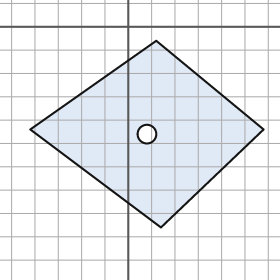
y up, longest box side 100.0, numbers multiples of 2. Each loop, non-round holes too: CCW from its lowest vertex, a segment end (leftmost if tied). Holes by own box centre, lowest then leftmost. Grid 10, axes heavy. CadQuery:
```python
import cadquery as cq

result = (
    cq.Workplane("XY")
    .moveTo(14.0, -86.0)
    .lineTo(58.0, -44.0)
    .lineTo(12.0, -6.0)
    .lineTo(-42.0, -44.0)
    .close()
    .moveTo(8.0, -46.0)
    .circle(4.0)
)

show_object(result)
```